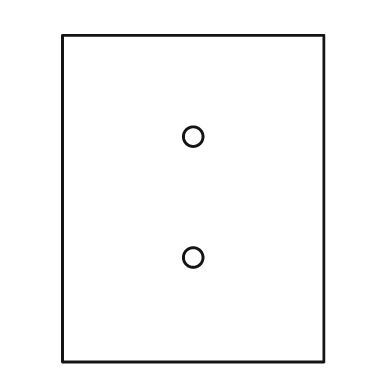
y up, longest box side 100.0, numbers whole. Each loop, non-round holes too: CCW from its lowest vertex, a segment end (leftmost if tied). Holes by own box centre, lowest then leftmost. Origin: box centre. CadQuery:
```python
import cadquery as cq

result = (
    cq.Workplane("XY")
    .moveTo(-40.0, -50.0)
    .lineTo(40.0, -50.0)
    .lineTo(40.0, 50.0)
    .lineTo(-40.0, 50.0)
    .close()
    .moveTo(0.0, -18.0)
    .circle(3.0)
    .moveTo(0.0, 19.0)
    .circle(3.0)
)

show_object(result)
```